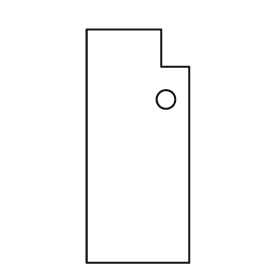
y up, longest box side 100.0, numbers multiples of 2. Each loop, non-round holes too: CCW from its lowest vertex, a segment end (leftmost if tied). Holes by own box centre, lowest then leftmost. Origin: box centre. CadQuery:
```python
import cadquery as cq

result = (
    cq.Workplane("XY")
    .moveTo(-22.0, -50.0)
    .lineTo(22.0, -50.0)
    .lineTo(22.0, 34.0)
    .lineTo(10.0, 34.0)
    .lineTo(10.0, 50.0)
    .lineTo(-22.0, 50.0)
    .close()
    .moveTo(12.0, 20.0)
    .circle(4.0)
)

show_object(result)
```